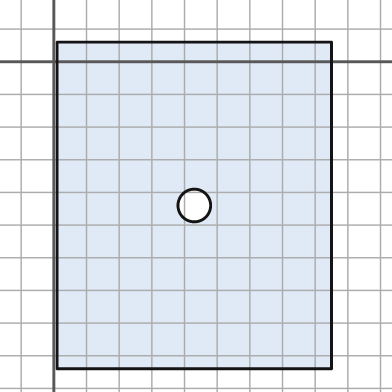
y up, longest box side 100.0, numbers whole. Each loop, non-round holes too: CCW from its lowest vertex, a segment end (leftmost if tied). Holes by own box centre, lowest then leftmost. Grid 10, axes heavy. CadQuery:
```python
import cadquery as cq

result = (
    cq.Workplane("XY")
    .moveTo(1.0, -94.0)
    .lineTo(85.0, -94.0)
    .lineTo(85.0, 6.0)
    .lineTo(1.0, 6.0)
    .close()
    .moveTo(43.0, -44.0)
    .circle(5.0)
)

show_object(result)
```